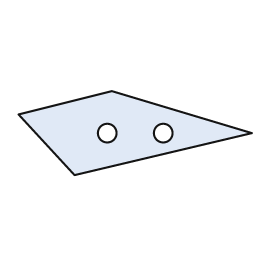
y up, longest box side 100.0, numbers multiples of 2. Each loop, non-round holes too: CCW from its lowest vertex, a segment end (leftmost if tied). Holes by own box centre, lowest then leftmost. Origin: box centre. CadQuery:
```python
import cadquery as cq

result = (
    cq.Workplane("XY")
    .moveTo(-26.0, -18.0)
    .lineTo(50.0, 0.0)
    .lineTo(-10.0, 18.0)
    .lineTo(-50.0, 8.0)
    .close()
    .moveTo(-12.0, 0.0)
    .circle(4.0)
    .moveTo(12.0, 0.0)
    .circle(4.0)
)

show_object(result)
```